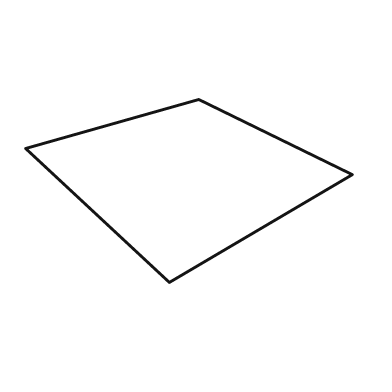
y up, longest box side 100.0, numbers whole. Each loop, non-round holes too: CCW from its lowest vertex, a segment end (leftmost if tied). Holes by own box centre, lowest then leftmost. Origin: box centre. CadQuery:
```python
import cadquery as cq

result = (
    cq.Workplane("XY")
    .moveTo(-6.0, -28.0)
    .lineTo(50.0, 5.0)
    .lineTo(3.0, 28.0)
    .lineTo(-50.0, 13.0)
    .close()
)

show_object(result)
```